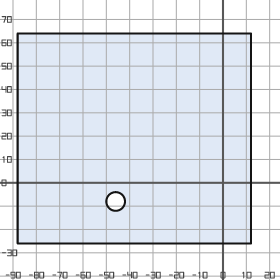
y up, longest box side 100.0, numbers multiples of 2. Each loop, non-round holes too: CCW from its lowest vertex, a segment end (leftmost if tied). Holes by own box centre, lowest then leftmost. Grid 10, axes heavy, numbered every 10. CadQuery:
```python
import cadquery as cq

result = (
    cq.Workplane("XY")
    .moveTo(-88.0, -26.0)
    .lineTo(12.0, -26.0)
    .lineTo(12.0, 64.0)
    .lineTo(-88.0, 64.0)
    .close()
    .moveTo(-46.0, -8.0)
    .circle(4.0)
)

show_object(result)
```